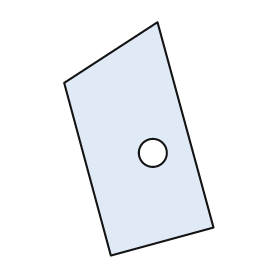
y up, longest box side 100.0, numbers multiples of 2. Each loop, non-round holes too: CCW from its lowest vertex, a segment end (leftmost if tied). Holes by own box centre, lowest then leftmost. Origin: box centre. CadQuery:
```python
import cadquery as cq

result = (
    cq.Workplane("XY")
    .moveTo(-12.0, -50.0)
    .lineTo(32.0, -38.0)
    .lineTo(8.0, 50.0)
    .lineTo(-32.0, 24.0)
    .close()
    .moveTo(6.0, -6.0)
    .circle(6.0)
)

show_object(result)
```